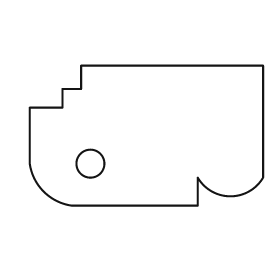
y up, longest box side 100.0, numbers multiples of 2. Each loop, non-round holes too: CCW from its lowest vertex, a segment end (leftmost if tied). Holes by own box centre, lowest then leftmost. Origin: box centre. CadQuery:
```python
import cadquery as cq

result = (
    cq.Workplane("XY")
    .moveTo(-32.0, -30.0)
    .lineTo(22.0, -30.0)
    .lineTo(22.0, -18.0)
    .threePointArc((36.0, -26.0), (50.0, -18.0))
    .lineTo(50.0, 30.0)
    .lineTo(-28.0, 30.0)
    .lineTo(-28.0, 20.0)
    .lineTo(-36.0, 20.0)
    .lineTo(-36.0, 12.0)
    .lineTo(-50.0, 12.0)
    .lineTo(-50.0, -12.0)
    .threePointArc((-44.0, -24.0), (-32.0, -30.0))
    .close()
    .moveTo(-24.0, -12.0)
    .circle(6.0)
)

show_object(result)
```